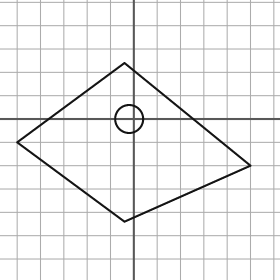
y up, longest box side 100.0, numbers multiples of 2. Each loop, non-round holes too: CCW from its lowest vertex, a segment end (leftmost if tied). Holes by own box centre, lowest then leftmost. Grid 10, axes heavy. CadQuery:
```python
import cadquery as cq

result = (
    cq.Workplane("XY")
    .moveTo(-4.0, -44.0)
    .lineTo(50.0, -20.0)
    .lineTo(-4.0, 24.0)
    .lineTo(-50.0, -10.0)
    .close()
    .moveTo(-2.0, 0.0)
    .circle(6.0)
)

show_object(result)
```